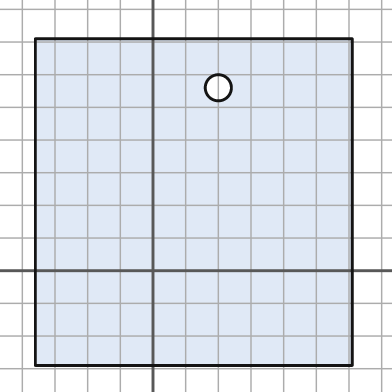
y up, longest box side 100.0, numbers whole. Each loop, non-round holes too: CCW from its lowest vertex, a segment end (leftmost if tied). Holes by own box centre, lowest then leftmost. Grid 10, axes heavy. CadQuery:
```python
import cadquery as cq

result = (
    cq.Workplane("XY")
    .moveTo(-36.0, -29.0)
    .lineTo(61.0, -29.0)
    .lineTo(61.0, 71.0)
    .lineTo(-36.0, 71.0)
    .close()
    .moveTo(20.0, 56.0)
    .circle(4.0)
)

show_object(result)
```